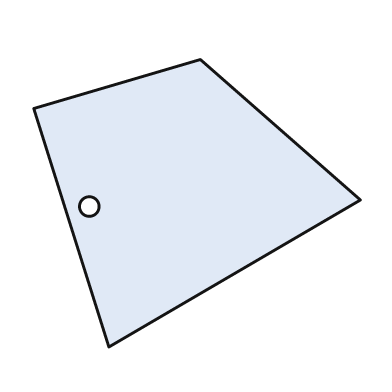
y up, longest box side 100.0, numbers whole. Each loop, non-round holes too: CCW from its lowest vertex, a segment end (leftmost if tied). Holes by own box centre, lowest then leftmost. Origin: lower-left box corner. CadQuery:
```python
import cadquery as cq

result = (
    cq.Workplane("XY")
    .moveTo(23.0, 0.0)
    .lineTo(100.0, 45.0)
    .lineTo(51.0, 88.0)
    .lineTo(0.0, 73.0)
    .close()
    .moveTo(17.0, 43.0)
    .circle(3.0)
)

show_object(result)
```